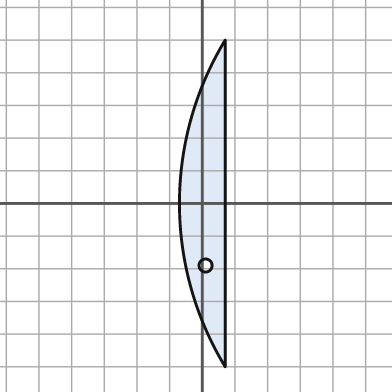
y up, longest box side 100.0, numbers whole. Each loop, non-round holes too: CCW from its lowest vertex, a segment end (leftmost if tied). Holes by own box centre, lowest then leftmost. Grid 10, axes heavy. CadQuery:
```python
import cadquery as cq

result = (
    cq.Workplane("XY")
    .moveTo(7.0, -50.0)
    .lineTo(7.0, 50.0)
    .threePointArc((-7.0, 0.0), (7.0, -50.0))
    .close()
    .moveTo(1.0, -19.0)
    .circle(2.0)
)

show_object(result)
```